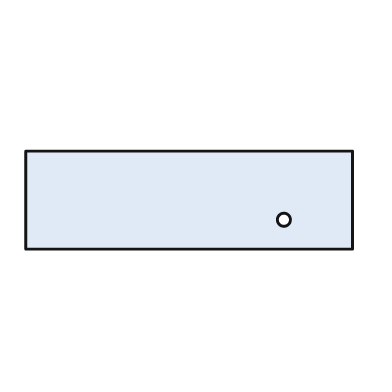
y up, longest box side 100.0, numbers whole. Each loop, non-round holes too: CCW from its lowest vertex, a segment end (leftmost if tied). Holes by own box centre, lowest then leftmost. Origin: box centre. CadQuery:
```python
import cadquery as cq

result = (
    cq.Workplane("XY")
    .moveTo(-50.0, -15.0)
    .lineTo(50.0, -15.0)
    .lineTo(50.0, 15.0)
    .lineTo(-50.0, 15.0)
    .close()
    .moveTo(29.0, -6.0)
    .circle(2.0)
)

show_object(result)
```